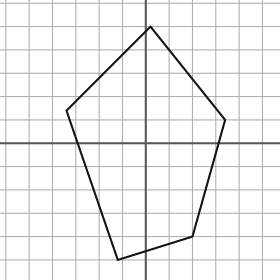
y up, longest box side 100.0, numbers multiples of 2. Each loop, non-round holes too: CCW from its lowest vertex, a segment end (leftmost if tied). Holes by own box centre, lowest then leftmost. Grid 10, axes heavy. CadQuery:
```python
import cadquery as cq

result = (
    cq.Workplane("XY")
    .moveTo(-12.0, -50.0)
    .lineTo(20.0, -40.0)
    .lineTo(34.0, 10.0)
    .lineTo(2.0, 50.0)
    .lineTo(-34.0, 14.0)
    .close()
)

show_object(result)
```